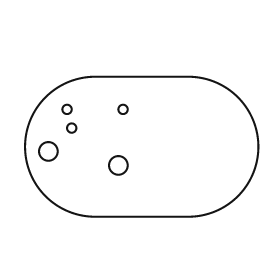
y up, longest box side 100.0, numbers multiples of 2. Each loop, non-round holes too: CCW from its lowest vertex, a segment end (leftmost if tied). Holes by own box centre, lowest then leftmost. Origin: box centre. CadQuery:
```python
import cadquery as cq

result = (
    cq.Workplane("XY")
    .moveTo(-20.0, -30.0)
    .lineTo(20.0, -30.0)
    .threePointArc((50.0, 0.0), (20.0, 30.0))
    .lineTo(-20.0, 30.0)
    .threePointArc((-50.0, 0.0), (-20.0, -30.0))
    .close()
    .moveTo(-10.0, -8.0)
    .circle(4.0)
    .moveTo(-40.0, -2.0)
    .circle(4.0)
    .moveTo(-30.0, 8.0)
    .circle(2.0)
    .moveTo(-32.0, 16.0)
    .circle(2.0)
    .moveTo(-8.0, 16.0)
    .circle(2.0)
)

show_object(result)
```